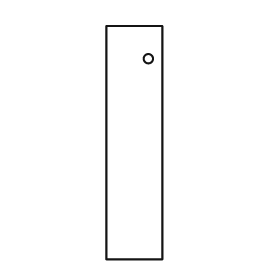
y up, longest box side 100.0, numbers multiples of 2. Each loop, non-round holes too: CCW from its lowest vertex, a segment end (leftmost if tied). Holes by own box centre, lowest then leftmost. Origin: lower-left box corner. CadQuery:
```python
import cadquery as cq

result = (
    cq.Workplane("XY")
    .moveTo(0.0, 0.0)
    .lineTo(24.0, 0.0)
    .lineTo(24.0, 100.0)
    .lineTo(0.0, 100.0)
    .close()
    .moveTo(18.0, 86.0)
    .circle(2.0)
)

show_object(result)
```